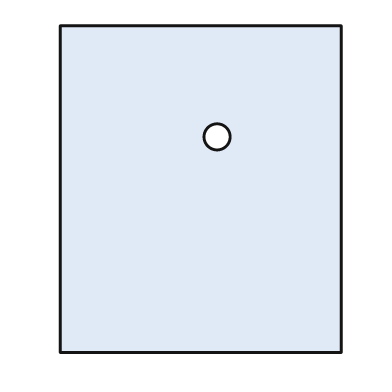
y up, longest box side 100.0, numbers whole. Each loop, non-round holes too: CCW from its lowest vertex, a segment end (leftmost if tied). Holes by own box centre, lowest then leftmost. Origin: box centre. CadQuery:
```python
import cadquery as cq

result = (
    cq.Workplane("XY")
    .moveTo(-43.0, -50.0)
    .lineTo(43.0, -50.0)
    .lineTo(43.0, 50.0)
    .lineTo(-43.0, 50.0)
    .close()
    .moveTo(5.0, 16.0)
    .circle(4.0)
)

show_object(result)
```